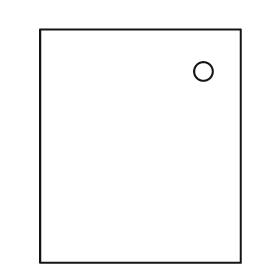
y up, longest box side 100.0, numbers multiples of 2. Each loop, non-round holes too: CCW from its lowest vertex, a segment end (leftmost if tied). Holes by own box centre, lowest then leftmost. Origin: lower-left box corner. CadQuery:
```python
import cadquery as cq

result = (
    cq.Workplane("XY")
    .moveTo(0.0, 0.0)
    .lineTo(86.0, 0.0)
    .lineTo(86.0, 100.0)
    .lineTo(0.0, 100.0)
    .close()
    .moveTo(70.0, 82.0)
    .circle(4.0)
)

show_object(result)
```